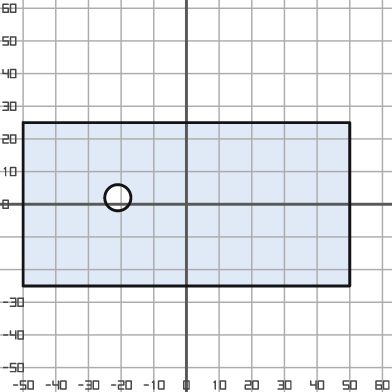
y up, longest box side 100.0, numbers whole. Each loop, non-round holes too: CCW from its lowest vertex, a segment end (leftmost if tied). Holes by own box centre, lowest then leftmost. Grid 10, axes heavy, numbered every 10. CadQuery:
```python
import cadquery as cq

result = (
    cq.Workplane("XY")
    .moveTo(-50.0, -25.0)
    .lineTo(50.0, -25.0)
    .lineTo(50.0, 25.0)
    .lineTo(-50.0, 25.0)
    .close()
    .moveTo(-21.0, 2.0)
    .circle(4.0)
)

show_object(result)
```